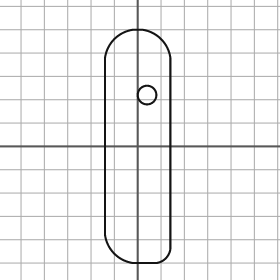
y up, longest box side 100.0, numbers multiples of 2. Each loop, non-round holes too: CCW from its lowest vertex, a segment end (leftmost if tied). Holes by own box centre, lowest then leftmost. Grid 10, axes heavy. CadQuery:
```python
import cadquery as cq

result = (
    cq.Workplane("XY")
    .moveTo(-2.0, -50.0)
    .lineTo(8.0, -50.0)
    .threePointArc((12.0, -48.0), (14.0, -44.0))
    .lineTo(14.0, 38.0)
    .threePointArc((10.0, 46.0), (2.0, 50.0))
    .lineTo(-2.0, 50.0)
    .threePointArc((-10.0, 46.0), (-14.0, 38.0))
    .lineTo(-14.0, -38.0)
    .threePointArc((-10.0, -46.0), (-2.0, -50.0))
    .close()
    .moveTo(4.0, 22.0)
    .circle(4.0)
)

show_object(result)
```